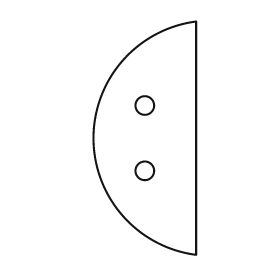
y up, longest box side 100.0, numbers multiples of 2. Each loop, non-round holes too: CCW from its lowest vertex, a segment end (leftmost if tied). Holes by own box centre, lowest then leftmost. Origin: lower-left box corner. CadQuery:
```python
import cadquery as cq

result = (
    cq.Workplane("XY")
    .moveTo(44.0, 0.0)
    .lineTo(44.0, 100.0)
    .threePointArc((0.0, 50.0), (44.0, 0.0))
    .close()
    .moveTo(22.0, 36.0)
    .circle(4.0)
    .moveTo(22.0, 64.0)
    .circle(4.0)
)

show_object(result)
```